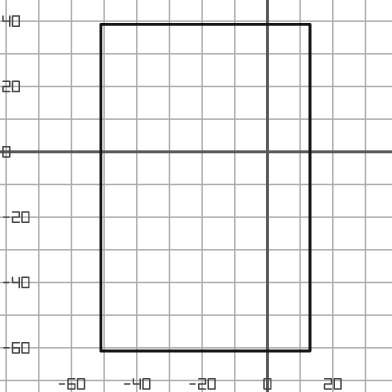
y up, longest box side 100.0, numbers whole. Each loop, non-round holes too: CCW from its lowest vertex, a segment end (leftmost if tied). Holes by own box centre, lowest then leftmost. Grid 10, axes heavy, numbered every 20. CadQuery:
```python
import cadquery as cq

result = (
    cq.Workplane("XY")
    .moveTo(-51.0, -61.0)
    .lineTo(13.0, -61.0)
    .lineTo(13.0, 39.0)
    .lineTo(-51.0, 39.0)
    .close()
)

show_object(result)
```